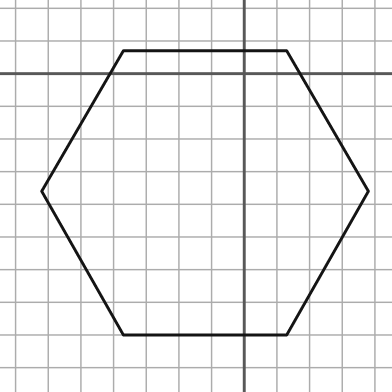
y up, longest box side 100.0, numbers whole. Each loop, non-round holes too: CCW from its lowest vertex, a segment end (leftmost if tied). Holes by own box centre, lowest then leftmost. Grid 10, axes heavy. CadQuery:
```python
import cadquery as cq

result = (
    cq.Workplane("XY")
    .moveTo(-37.0, -80.0)
    .lineTo(13.0, -80.0)
    .lineTo(38.0, -36.0)
    .lineTo(13.0, 7.0)
    .lineTo(-37.0, 7.0)
    .lineTo(-62.0, -36.0)
    .close()
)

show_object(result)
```